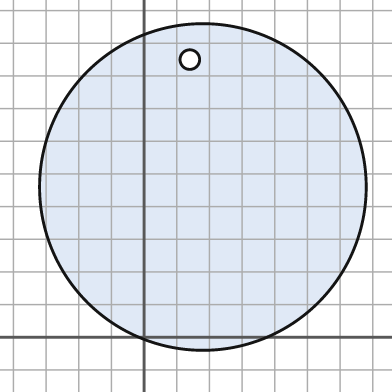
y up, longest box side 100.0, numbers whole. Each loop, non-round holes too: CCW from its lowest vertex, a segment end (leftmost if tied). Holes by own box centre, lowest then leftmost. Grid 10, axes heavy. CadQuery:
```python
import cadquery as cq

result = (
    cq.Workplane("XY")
    .moveTo(18.0, 46.0)
    .circle(50.0)
    .moveTo(14.0, 85.0)
    .circle(3.0)
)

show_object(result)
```